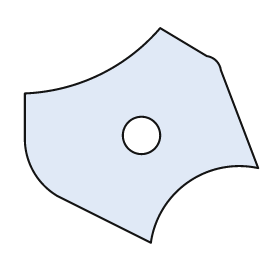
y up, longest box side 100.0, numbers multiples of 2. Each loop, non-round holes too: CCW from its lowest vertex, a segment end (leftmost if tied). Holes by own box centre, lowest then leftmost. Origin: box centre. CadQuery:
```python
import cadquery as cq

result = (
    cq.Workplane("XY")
    .moveTo(4.0, -46.0)
    .threePointArc((20.0, -20.0), (50.0, -14.0))
    .lineTo(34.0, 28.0)
    .threePointArc((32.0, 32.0), (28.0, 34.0))
    .lineTo(8.0, 46.0)
    .threePointArc((-18.0, 26.0), (-50.0, 18.0))
    .lineTo(-50.0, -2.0)
    .threePointArc((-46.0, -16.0), (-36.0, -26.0))
    .close()
    .moveTo(0.0, 0.0)
    .circle(8.0)
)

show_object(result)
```